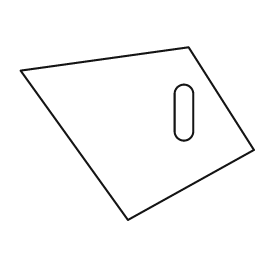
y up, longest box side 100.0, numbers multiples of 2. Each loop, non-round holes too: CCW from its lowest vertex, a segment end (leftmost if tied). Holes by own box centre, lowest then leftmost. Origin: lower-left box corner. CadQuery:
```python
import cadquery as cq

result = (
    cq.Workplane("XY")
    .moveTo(46.0, 0.0)
    .lineTo(100.0, 30.0)
    .lineTo(72.0, 74.0)
    .lineTo(0.0, 64.0)
    .close()
    .moveTo(66.0, 38.0)
    .threePointArc((70.0, 34.0), (74.0, 38.0))
    .lineTo(74.0, 54.0)
    .threePointArc((70.0, 58.0), (66.0, 54.0))
    .close()
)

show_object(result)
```